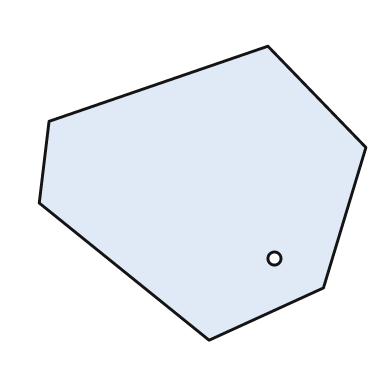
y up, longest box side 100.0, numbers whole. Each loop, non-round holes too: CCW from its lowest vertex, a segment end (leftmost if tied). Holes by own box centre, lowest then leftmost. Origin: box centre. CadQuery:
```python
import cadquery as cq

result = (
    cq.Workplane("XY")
    .moveTo(2.0, -45.0)
    .lineTo(37.0, -29.0)
    .lineTo(50.0, 14.0)
    .lineTo(20.0, 45.0)
    .lineTo(-47.0, 22.0)
    .lineTo(-50.0, -3.0)
    .close()
    .moveTo(22.0, -20.0)
    .circle(2.0)
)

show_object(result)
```